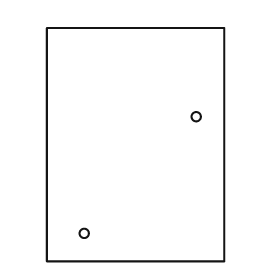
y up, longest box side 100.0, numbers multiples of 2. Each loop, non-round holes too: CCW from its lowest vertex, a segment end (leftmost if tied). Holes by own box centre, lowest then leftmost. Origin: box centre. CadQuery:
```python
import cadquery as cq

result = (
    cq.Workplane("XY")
    .moveTo(-38.0, -50.0)
    .lineTo(38.0, -50.0)
    .lineTo(38.0, 50.0)
    .lineTo(-38.0, 50.0)
    .close()
    .moveTo(-22.0, -38.0)
    .circle(2.0)
    .moveTo(26.0, 12.0)
    .circle(2.0)
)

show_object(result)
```